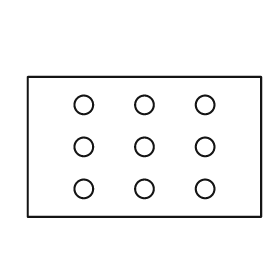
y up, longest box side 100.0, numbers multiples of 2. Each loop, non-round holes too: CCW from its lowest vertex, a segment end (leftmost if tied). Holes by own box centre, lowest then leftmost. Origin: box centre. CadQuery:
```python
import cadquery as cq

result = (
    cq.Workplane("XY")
    .moveTo(-50.0, -30.0)
    .lineTo(50.0, -30.0)
    .lineTo(50.0, 30.0)
    .lineTo(-50.0, 30.0)
    .close()
    .moveTo(-26.0, -18.0)
    .circle(4.0)
    .moveTo(0.0, -18.0)
    .circle(4.0)
    .moveTo(26.0, -18.0)
    .circle(4.0)
    .moveTo(-26.0, 0.0)
    .circle(4.0)
    .moveTo(0.0, 0.0)
    .circle(4.0)
    .moveTo(26.0, 0.0)
    .circle(4.0)
    .moveTo(-26.0, 18.0)
    .circle(4.0)
    .moveTo(0.0, 18.0)
    .circle(4.0)
    .moveTo(26.0, 18.0)
    .circle(4.0)
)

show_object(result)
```